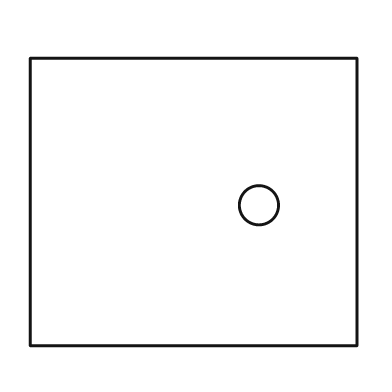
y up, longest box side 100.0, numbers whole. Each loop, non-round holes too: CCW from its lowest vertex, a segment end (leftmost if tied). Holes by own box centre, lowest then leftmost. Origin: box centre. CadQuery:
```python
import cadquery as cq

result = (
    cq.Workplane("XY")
    .moveTo(-50.0, -44.0)
    .lineTo(50.0, -44.0)
    .lineTo(50.0, 44.0)
    .lineTo(-50.0, 44.0)
    .close()
    .moveTo(20.0, -1.0)
    .circle(6.0)
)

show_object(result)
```